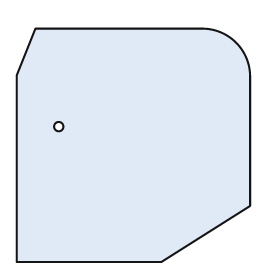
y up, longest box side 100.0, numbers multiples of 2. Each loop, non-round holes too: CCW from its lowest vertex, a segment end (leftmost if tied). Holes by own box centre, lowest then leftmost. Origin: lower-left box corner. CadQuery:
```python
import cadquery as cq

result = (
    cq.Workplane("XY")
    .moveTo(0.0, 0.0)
    .lineTo(62.0, 0.0)
    .lineTo(100.0, 24.0)
    .lineTo(100.0, 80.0)
    .threePointArc((94.0, 94.0), (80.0, 100.0))
    .lineTo(8.0, 100.0)
    .lineTo(0.0, 80.0)
    .close()
    .moveTo(18.0, 58.0)
    .circle(2.0)
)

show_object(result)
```